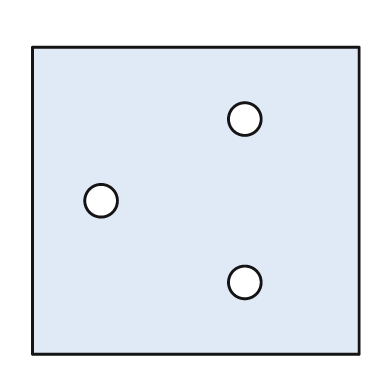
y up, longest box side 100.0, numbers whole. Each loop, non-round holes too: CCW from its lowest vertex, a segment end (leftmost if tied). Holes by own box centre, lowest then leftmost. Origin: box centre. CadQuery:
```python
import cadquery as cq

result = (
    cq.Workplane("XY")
    .moveTo(-50.0, -47.0)
    .lineTo(50.0, -47.0)
    .lineTo(50.0, 47.0)
    .lineTo(-50.0, 47.0)
    .close()
    .moveTo(15.0, -25.0)
    .circle(5.0)
    .moveTo(-29.0, 0.0)
    .circle(5.0)
    .moveTo(15.0, 25.0)
    .circle(5.0)
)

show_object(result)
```